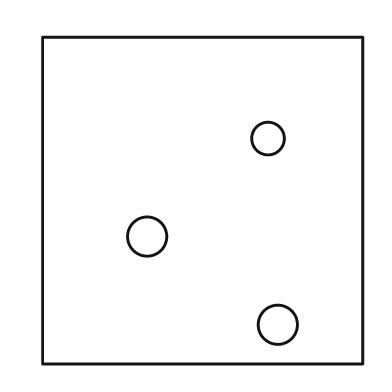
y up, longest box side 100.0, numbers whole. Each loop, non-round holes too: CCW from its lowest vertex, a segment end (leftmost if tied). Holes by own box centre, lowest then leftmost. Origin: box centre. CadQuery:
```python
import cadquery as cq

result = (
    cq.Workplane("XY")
    .moveTo(-49.0, -50.0)
    .lineTo(49.0, -50.0)
    .lineTo(49.0, 50.0)
    .lineTo(-49.0, 50.0)
    .close()
    .moveTo(23.0, -38.0)
    .circle(6.0)
    .moveTo(-17.0, -11.0)
    .circle(6.0)
    .moveTo(20.0, 19.0)
    .circle(5.0)
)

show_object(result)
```